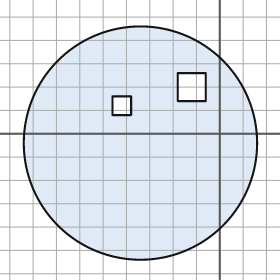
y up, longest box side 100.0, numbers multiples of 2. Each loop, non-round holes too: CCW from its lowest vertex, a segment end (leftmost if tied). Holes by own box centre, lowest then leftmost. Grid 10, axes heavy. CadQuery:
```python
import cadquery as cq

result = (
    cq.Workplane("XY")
    .moveTo(-34.0, -4.0)
    .circle(50.0)
    .moveTo(-46.0, 8.0)
    .lineTo(-38.0, 8.0)
    .lineTo(-38.0, 16.0)
    .lineTo(-46.0, 16.0)
    .close()
    .moveTo(-18.0, 14.0)
    .lineTo(-6.0, 14.0)
    .lineTo(-6.0, 26.0)
    .lineTo(-18.0, 26.0)
    .close()
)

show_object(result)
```